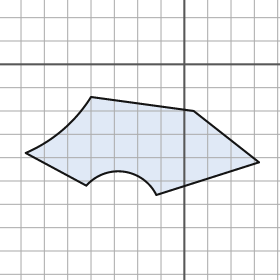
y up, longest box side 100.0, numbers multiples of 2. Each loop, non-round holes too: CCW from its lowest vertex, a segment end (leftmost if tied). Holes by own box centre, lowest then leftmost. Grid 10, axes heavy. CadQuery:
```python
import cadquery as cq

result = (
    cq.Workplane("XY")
    .moveTo(-12.0, -56.0)
    .lineTo(32.0, -42.0)
    .lineTo(4.0, -20.0)
    .lineTo(-40.0, -14.0)
    .threePointArc((-52.0, -28.0), (-68.0, -38.0))
    .lineTo(-42.0, -52.0)
    .threePointArc((-26.0, -46.0), (-12.0, -56.0))
    .close()
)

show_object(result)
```